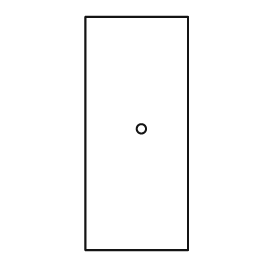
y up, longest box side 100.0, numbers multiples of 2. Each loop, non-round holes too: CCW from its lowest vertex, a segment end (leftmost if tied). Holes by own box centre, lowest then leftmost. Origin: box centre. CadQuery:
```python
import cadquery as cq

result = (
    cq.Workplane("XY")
    .moveTo(-22.0, -50.0)
    .lineTo(22.0, -50.0)
    .lineTo(22.0, 50.0)
    .lineTo(-22.0, 50.0)
    .close()
    .moveTo(2.0, 2.0)
    .circle(2.0)
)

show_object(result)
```